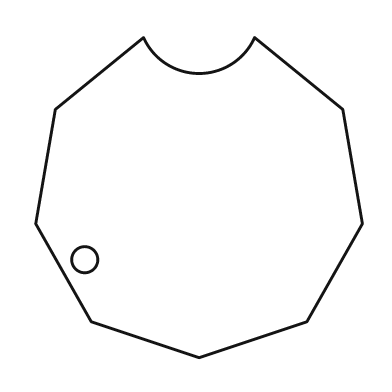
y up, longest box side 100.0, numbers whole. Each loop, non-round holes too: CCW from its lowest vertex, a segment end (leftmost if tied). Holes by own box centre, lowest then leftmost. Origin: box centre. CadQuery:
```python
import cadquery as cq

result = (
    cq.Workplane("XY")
    .moveTo(0.0, -49.0)
    .lineTo(33.0, -38.0)
    .lineTo(50.0, -8.0)
    .lineTo(44.0, 27.0)
    .lineTo(17.0, 49.0)
    .threePointArc((0.0, 38.0), (-17.0, 49.0))
    .lineTo(-44.0, 27.0)
    .lineTo(-50.0, -8.0)
    .lineTo(-33.0, -38.0)
    .close()
    .moveTo(-35.0, -19.0)
    .circle(4.0)
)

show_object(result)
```